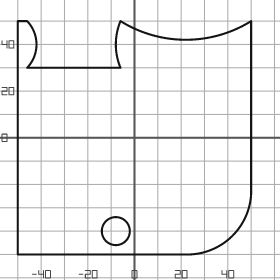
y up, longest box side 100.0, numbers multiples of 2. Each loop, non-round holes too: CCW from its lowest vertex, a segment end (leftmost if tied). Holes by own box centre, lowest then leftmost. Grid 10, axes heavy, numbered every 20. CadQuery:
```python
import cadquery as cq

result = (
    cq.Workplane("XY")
    .moveTo(-50.0, -50.0)
    .lineTo(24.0, -50.0)
    .threePointArc((42.0, -42.0), (50.0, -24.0))
    .lineTo(50.0, 50.0)
    .threePointArc((22.0, 42.0), (-6.0, 50.0))
    .threePointArc((-8.0, 40.0), (-6.0, 30.0))
    .lineTo(-46.0, 30.0)
    .threePointArc((-42.0, 40.0), (-46.0, 50.0))
    .lineTo(-50.0, 50.0)
    .close()
    .moveTo(-8.0, -40.0)
    .circle(6.0)
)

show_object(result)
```